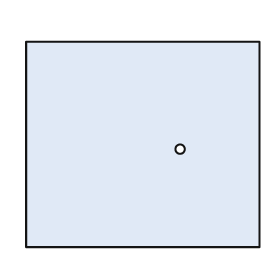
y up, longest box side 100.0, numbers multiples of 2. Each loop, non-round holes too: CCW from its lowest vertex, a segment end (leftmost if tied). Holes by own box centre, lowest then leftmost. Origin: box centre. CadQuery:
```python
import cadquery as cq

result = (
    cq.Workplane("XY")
    .moveTo(-50.0, -44.0)
    .lineTo(50.0, -44.0)
    .lineTo(50.0, 44.0)
    .lineTo(-50.0, 44.0)
    .close()
    .moveTo(16.0, -2.0)
    .circle(2.0)
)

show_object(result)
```